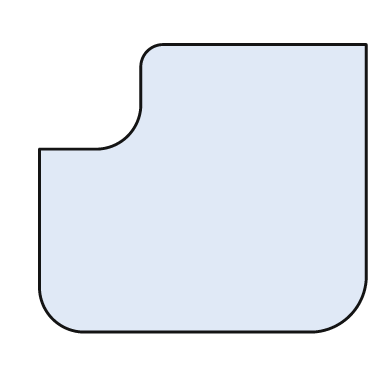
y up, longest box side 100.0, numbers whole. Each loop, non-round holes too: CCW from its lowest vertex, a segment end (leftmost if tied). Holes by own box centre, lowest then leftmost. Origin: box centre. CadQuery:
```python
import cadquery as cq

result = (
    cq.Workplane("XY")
    .moveTo(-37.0, -44.0)
    .lineTo(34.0, -44.0)
    .threePointArc((45.0, -39.0), (50.0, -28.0))
    .lineTo(50.0, 44.0)
    .lineTo(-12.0, 44.0)
    .threePointArc((-17.0, 42.0), (-19.0, 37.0))
    .lineTo(-19.0, 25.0)
    .threePointArc((-23.0, 16.0), (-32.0, 12.0))
    .lineTo(-50.0, 12.0)
    .lineTo(-50.0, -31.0)
    .threePointArc((-46.0, -40.0), (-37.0, -44.0))
    .close()
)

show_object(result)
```